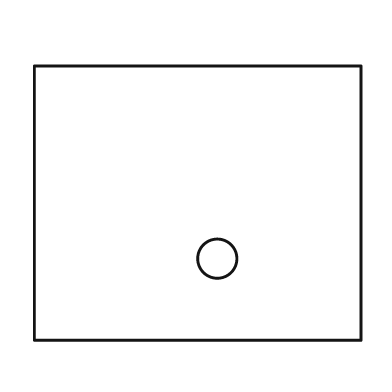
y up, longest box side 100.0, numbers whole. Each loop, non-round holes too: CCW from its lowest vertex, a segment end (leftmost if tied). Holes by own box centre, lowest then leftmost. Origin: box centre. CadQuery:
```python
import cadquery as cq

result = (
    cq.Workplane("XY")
    .moveTo(-50.0, -42.0)
    .lineTo(50.0, -42.0)
    .lineTo(50.0, 42.0)
    .lineTo(-50.0, 42.0)
    .close()
    .moveTo(6.0, -17.0)
    .circle(6.0)
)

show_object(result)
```